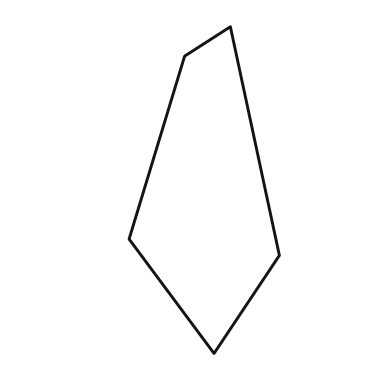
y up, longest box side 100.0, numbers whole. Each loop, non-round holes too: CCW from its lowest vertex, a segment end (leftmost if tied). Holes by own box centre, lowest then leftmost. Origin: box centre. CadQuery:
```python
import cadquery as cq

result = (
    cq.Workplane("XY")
    .moveTo(3.0, -50.0)
    .lineTo(23.0, -20.0)
    .lineTo(8.0, 50.0)
    .lineTo(-6.0, 41.0)
    .lineTo(-23.0, -15.0)
    .close()
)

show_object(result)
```